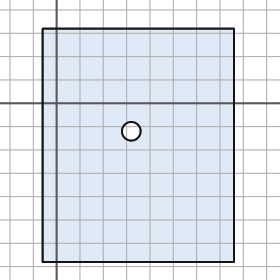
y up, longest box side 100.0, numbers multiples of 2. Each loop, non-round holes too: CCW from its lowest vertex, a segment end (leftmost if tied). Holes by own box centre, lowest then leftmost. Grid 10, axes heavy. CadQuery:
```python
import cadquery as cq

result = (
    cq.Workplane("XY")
    .moveTo(-6.0, -68.0)
    .lineTo(76.0, -68.0)
    .lineTo(76.0, 32.0)
    .lineTo(-6.0, 32.0)
    .close()
    .moveTo(32.0, -12.0)
    .circle(4.0)
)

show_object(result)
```